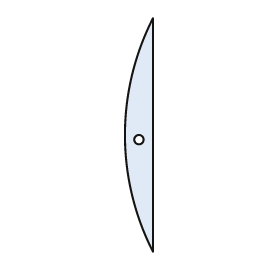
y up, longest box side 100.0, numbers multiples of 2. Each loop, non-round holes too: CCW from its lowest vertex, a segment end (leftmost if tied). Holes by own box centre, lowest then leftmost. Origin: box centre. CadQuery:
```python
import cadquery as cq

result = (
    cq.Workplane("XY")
    .moveTo(6.0, -50.0)
    .lineTo(6.0, 50.0)
    .threePointArc((-6.0, 0.0), (6.0, -50.0))
    .close()
    .moveTo(0.0, -2.0)
    .circle(2.0)
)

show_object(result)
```